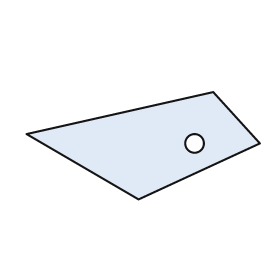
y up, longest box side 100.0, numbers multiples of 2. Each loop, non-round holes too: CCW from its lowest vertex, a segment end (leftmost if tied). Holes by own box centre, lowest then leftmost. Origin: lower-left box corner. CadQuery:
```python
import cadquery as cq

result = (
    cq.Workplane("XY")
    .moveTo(48.0, 0.0)
    .lineTo(100.0, 24.0)
    .lineTo(80.0, 46.0)
    .lineTo(0.0, 28.0)
    .close()
    .moveTo(72.0, 24.0)
    .circle(4.0)
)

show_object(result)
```